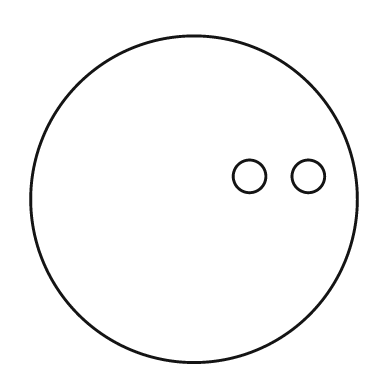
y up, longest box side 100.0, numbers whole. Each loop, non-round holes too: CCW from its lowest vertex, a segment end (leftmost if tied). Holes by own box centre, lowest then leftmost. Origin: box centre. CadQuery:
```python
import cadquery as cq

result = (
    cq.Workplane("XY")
    .moveTo(0.0, 0.0)
    .circle(50.0)
    .moveTo(17.0, 7.0)
    .circle(5.0)
    .moveTo(35.0, 7.0)
    .circle(5.0)
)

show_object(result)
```